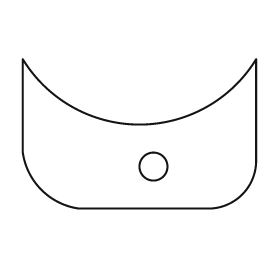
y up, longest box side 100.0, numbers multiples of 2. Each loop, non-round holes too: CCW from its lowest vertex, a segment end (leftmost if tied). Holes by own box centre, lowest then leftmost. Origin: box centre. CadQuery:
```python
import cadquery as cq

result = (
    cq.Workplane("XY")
    .moveTo(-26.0, -32.0)
    .lineTo(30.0, -32.0)
    .threePointArc((44.0, -26.0), (50.0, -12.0))
    .lineTo(50.0, 32.0)
    .threePointArc((0.0, 4.0), (-50.0, 32.0))
    .lineTo(-50.0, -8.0)
    .threePointArc((-42.0, -24.0), (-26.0, -32.0))
    .close()
    .moveTo(6.0, -14.0)
    .circle(6.0)
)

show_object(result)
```